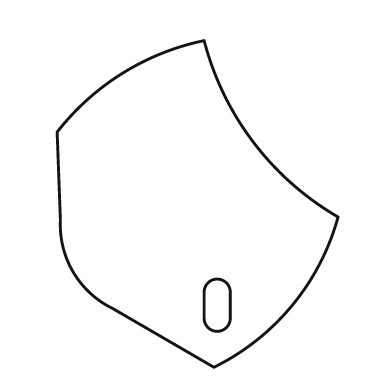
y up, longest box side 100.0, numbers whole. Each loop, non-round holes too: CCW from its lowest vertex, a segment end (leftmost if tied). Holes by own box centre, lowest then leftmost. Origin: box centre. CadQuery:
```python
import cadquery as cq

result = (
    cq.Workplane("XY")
    .moveTo(5.0, -50.0)
    .threePointArc((29.0, -31.0), (43.0, -4.0))
    .threePointArc((17.0, 19.0), (2.0, 50.0))
    .threePointArc((-23.0, 40.0), (-43.0, 22.0))
    .lineTo(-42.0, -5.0)
    .threePointArc((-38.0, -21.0), (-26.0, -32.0))
    .close()
    .moveTo(2.0, -35.0)
    .threePointArc((6.0, -39.0), (10.0, -35.0))
    .lineTo(10.0, -27.0)
    .threePointArc((6.0, -23.0), (2.0, -27.0))
    .close()
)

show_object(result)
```